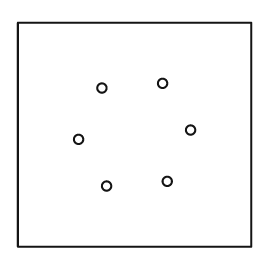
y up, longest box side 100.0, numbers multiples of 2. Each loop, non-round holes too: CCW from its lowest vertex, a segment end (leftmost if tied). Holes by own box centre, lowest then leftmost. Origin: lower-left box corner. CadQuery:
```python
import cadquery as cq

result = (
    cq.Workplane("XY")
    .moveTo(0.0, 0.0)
    .lineTo(100.0, 0.0)
    .lineTo(100.0, 96.0)
    .lineTo(0.0, 96.0)
    .close()
    .moveTo(38.0, 26.0)
    .circle(2.0)
    .moveTo(64.0, 28.0)
    .circle(2.0)
    .moveTo(26.0, 46.0)
    .circle(2.0)
    .moveTo(74.0, 50.0)
    .circle(2.0)
    .moveTo(36.0, 68.0)
    .circle(2.0)
    .moveTo(62.0, 70.0)
    .circle(2.0)
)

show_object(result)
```